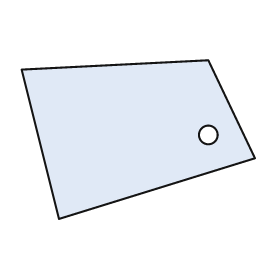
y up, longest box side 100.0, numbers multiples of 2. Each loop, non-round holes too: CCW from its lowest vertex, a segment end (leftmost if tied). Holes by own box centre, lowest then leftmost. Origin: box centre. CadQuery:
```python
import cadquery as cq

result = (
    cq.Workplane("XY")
    .moveTo(-34.0, -34.0)
    .lineTo(50.0, -8.0)
    .lineTo(30.0, 34.0)
    .lineTo(-50.0, 30.0)
    .close()
    .moveTo(30.0, 2.0)
    .circle(4.0)
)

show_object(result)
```